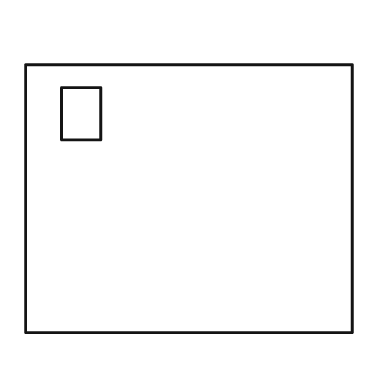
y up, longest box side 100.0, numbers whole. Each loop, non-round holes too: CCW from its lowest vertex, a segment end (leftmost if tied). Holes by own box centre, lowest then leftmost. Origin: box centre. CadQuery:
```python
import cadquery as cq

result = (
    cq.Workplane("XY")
    .moveTo(-50.0, -41.0)
    .lineTo(50.0, -41.0)
    .lineTo(50.0, 41.0)
    .lineTo(-50.0, 41.0)
    .close()
    .moveTo(-39.0, 18.0)
    .lineTo(-27.0, 18.0)
    .lineTo(-27.0, 34.0)
    .lineTo(-39.0, 34.0)
    .close()
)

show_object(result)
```